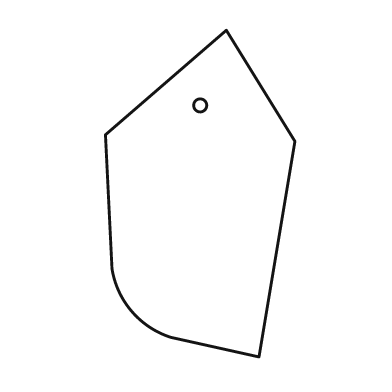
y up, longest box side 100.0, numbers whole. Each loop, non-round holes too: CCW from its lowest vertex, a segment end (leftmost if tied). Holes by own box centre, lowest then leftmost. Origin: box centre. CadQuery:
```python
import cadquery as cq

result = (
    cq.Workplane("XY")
    .moveTo(18.0, -50.0)
    .lineTo(29.0, 16.0)
    .lineTo(8.0, 50.0)
    .lineTo(-29.0, 18.0)
    .lineTo(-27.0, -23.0)
    .threePointArc((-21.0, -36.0), (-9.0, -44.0))
    .close()
    .moveTo(0.0, 27.0)
    .circle(2.0)
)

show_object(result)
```